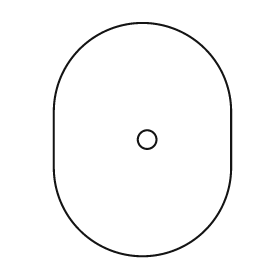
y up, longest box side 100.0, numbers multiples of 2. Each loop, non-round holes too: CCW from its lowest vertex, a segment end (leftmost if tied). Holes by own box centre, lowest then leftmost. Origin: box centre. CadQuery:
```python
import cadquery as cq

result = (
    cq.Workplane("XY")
    .moveTo(-38.0, -12.0)
    .threePointArc((0.0, -50.0), (38.0, -12.0))
    .lineTo(38.0, 12.0)
    .threePointArc((0.0, 50.0), (-38.0, 12.0))
    .close()
    .moveTo(2.0, 0.0)
    .circle(4.0)
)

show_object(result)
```